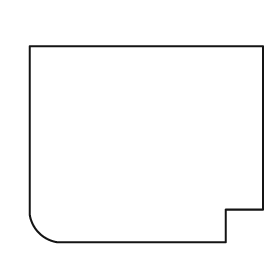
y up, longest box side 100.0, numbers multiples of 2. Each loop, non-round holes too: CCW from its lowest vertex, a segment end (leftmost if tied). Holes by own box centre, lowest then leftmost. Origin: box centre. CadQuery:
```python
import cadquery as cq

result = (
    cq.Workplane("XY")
    .moveTo(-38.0, -42.0)
    .lineTo(34.0, -42.0)
    .lineTo(34.0, -28.0)
    .lineTo(50.0, -28.0)
    .lineTo(50.0, 42.0)
    .lineTo(-50.0, 42.0)
    .lineTo(-50.0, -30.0)
    .threePointArc((-46.0, -38.0), (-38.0, -42.0))
    .close()
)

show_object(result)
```